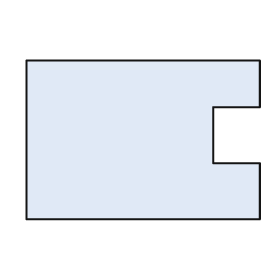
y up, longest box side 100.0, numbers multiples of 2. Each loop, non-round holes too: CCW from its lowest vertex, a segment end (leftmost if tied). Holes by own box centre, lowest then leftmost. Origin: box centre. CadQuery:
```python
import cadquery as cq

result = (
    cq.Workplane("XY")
    .moveTo(-50.0, -34.0)
    .lineTo(50.0, -34.0)
    .lineTo(50.0, -10.0)
    .lineTo(30.0, -10.0)
    .lineTo(30.0, 14.0)
    .lineTo(50.0, 14.0)
    .lineTo(50.0, 34.0)
    .lineTo(-50.0, 34.0)
    .close()
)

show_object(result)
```